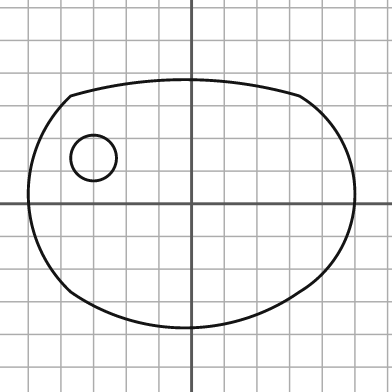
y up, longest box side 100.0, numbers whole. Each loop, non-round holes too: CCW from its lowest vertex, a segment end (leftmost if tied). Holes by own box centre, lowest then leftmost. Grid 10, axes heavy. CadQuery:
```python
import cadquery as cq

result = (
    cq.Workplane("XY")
    .moveTo(-37.0, -27.0)
    .threePointArc((-2.0, -38.0), (33.0, -27.0))
    .threePointArc((50.0, 3.0), (33.0, 33.0))
    .threePointArc((-2.0, 38.0), (-37.0, 33.0))
    .threePointArc((-50.0, 3.0), (-37.0, -27.0))
    .close()
    .moveTo(-30.0, 14.0)
    .circle(7.0)
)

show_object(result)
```